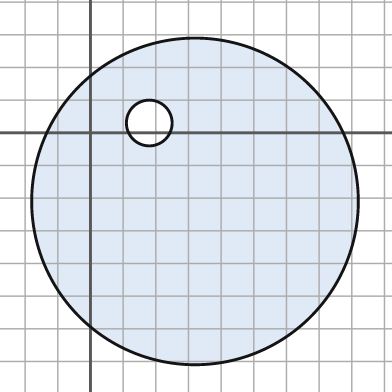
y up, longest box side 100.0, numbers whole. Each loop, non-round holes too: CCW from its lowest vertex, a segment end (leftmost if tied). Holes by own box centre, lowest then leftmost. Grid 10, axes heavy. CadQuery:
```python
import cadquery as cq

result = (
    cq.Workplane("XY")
    .moveTo(32.0, -21.0)
    .circle(50.0)
    .moveTo(18.0, 3.0)
    .circle(7.0)
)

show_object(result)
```